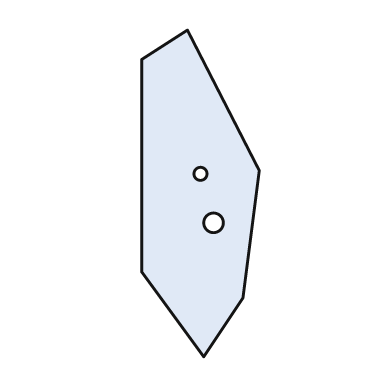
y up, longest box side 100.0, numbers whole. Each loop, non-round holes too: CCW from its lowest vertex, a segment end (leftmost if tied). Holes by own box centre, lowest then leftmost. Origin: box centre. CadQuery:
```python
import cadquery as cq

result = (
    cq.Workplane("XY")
    .moveTo(1.0, -50.0)
    .lineTo(13.0, -32.0)
    .lineTo(18.0, 7.0)
    .lineTo(-4.0, 50.0)
    .lineTo(-18.0, 41.0)
    .lineTo(-18.0, -24.0)
    .close()
    .moveTo(4.0, -9.0)
    .circle(3.0)
    .moveTo(0.0, 6.0)
    .circle(2.0)
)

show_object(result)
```